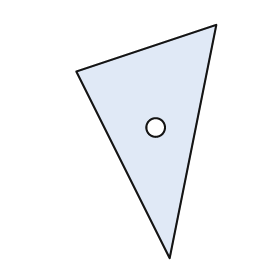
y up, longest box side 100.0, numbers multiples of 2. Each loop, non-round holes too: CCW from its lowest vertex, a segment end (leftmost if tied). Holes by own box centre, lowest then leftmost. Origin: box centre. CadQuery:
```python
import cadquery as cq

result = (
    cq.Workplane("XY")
    .moveTo(10.0, -50.0)
    .lineTo(30.0, 50.0)
    .lineTo(-30.0, 30.0)
    .close()
    .moveTo(4.0, 6.0)
    .circle(4.0)
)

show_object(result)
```